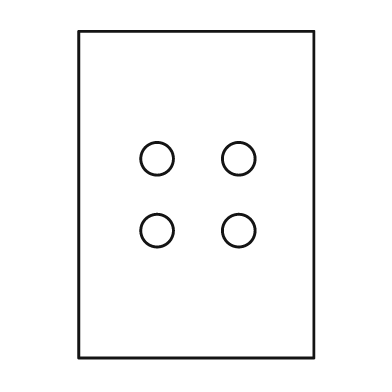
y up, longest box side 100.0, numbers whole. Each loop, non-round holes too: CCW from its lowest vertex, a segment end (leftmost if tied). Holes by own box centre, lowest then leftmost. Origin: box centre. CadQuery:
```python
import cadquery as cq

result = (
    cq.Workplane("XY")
    .moveTo(-36.0, -50.0)
    .lineTo(36.0, -50.0)
    .lineTo(36.0, 50.0)
    .lineTo(-36.0, 50.0)
    .close()
    .moveTo(-12.0, -11.0)
    .circle(5.0)
    .moveTo(13.0, -11.0)
    .circle(5.0)
    .moveTo(-12.0, 11.0)
    .circle(5.0)
    .moveTo(13.0, 11.0)
    .circle(5.0)
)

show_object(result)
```